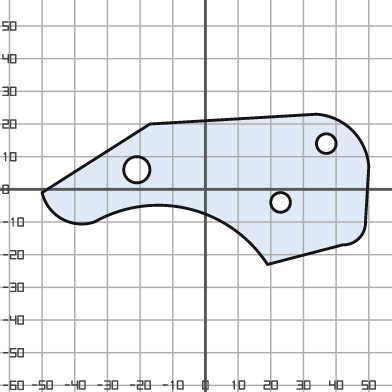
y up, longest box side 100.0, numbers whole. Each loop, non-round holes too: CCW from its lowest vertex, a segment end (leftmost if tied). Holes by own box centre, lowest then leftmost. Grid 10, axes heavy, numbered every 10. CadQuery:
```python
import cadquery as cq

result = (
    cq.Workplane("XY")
    .moveTo(19.0, -23.0)
    .lineTo(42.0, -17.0)
    .threePointArc((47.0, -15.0), (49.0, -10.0))
    .lineTo(50.0, 7.0)
    .threePointArc((45.0, 18.0), (34.0, 23.0))
    .lineTo(-17.0, 20.0)
    .lineTo(-50.0, -1.0)
    .threePointArc((-44.0, -9.0), (-34.0, -10.0))
    .threePointArc((-5.0, -6.0), (19.0, -23.0))
    .close()
    .moveTo(23.0, -4.0)
    .circle(3.0)
    .moveTo(-21.0, 6.0)
    .circle(4.0)
    .moveTo(37.0, 14.0)
    .circle(3.0)
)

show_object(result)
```